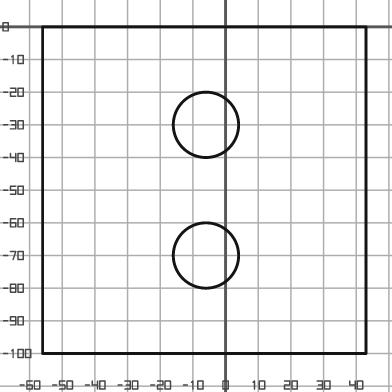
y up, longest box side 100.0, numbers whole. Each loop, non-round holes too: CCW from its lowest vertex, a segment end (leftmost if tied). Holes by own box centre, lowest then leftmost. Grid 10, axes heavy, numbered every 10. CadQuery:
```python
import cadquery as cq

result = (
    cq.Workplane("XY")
    .moveTo(-56.0, -100.0)
    .lineTo(43.0, -100.0)
    .lineTo(43.0, 0.0)
    .lineTo(-56.0, 0.0)
    .close()
    .moveTo(-6.0, -70.0)
    .circle(10.0)
    .moveTo(-6.0, -30.0)
    .circle(10.0)
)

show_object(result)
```